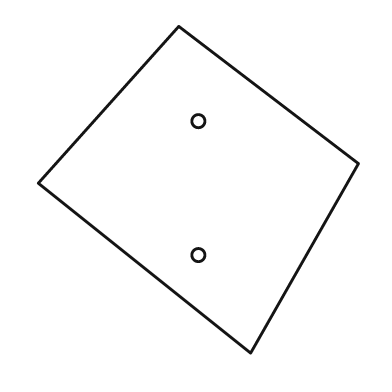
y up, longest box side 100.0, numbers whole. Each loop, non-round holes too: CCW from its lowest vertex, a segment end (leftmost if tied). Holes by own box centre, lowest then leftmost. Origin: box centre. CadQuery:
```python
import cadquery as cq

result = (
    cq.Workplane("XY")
    .moveTo(16.0, -50.0)
    .lineTo(49.0, 8.0)
    .lineTo(-6.0, 50.0)
    .lineTo(-49.0, 2.0)
    .close()
    .moveTo(0.0, -20.0)
    .circle(2.0)
    .moveTo(0.0, 21.0)
    .circle(2.0)
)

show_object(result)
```